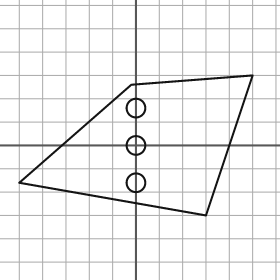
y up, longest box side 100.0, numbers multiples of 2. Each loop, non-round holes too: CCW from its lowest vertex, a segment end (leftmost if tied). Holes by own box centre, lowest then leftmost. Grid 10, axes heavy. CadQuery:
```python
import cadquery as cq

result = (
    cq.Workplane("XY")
    .moveTo(30.0, -30.0)
    .lineTo(50.0, 30.0)
    .lineTo(-2.0, 26.0)
    .lineTo(-50.0, -16.0)
    .close()
    .moveTo(0.0, -16.0)
    .circle(4.0)
    .moveTo(0.0, 0.0)
    .circle(4.0)
    .moveTo(0.0, 16.0)
    .circle(4.0)
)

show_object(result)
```